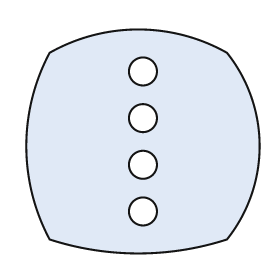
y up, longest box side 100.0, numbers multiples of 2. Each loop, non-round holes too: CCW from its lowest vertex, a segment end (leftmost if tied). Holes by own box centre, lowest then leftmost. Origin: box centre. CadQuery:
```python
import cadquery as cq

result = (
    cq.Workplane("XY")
    .moveTo(-40.0, -42.0)
    .threePointArc((-2.0, -48.0), (36.0, -42.0))
    .threePointArc((50.0, -2.0), (36.0, 38.0))
    .threePointArc((-2.0, 48.0), (-40.0, 38.0))
    .threePointArc((-50.0, -2.0), (-40.0, -42.0))
    .close()
    .moveTo(0.0, -30.0)
    .circle(6.0)
    .moveTo(0.0, -10.0)
    .circle(6.0)
    .moveTo(0.0, 10.0)
    .circle(6.0)
    .moveTo(0.0, 30.0)
    .circle(6.0)
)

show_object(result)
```